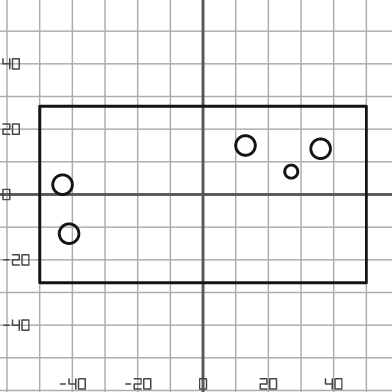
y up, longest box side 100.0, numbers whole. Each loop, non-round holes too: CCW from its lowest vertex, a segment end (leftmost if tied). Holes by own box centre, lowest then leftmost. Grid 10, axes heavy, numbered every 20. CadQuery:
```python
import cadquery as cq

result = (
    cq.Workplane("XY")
    .moveTo(-50.0, -27.0)
    .lineTo(50.0, -27.0)
    .lineTo(50.0, 27.0)
    .lineTo(-50.0, 27.0)
    .close()
    .moveTo(-41.0, -12.0)
    .circle(3.0)
    .moveTo(-43.0, 3.0)
    .circle(3.0)
    .moveTo(27.0, 7.0)
    .circle(2.0)
    .moveTo(36.0, 14.0)
    .circle(3.0)
    .moveTo(13.0, 15.0)
    .circle(3.0)
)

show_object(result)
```